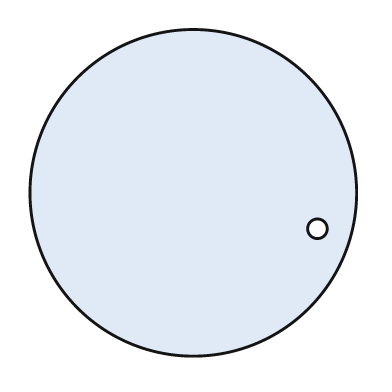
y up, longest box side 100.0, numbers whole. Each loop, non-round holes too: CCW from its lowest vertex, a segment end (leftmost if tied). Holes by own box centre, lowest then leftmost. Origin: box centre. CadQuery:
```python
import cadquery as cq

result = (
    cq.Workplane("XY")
    .moveTo(0.0, 0.0)
    .circle(50.0)
    .moveTo(38.0, -11.0)
    .circle(3.0)
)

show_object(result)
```